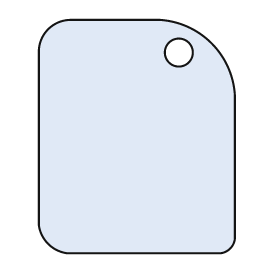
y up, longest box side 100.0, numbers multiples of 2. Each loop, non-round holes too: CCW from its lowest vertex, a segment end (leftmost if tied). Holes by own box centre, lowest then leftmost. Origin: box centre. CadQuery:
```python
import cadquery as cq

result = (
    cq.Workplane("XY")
    .moveTo(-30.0, -50.0)
    .lineTo(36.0, -50.0)
    .threePointArc((40.0, -48.0), (42.0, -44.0))
    .lineTo(42.0, 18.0)
    .threePointArc((32.0, 40.0), (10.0, 50.0))
    .lineTo(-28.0, 50.0)
    .threePointArc((-38.0, 46.0), (-42.0, 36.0))
    .lineTo(-42.0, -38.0)
    .threePointArc((-38.0, -46.0), (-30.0, -50.0))
    .close()
    .moveTo(18.0, 36.0)
    .circle(6.0)
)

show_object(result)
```